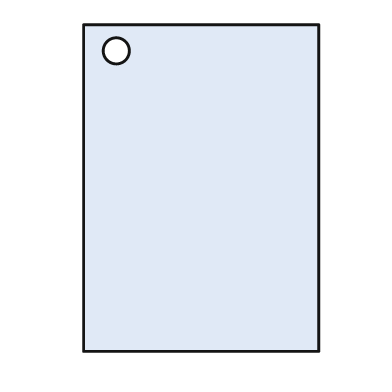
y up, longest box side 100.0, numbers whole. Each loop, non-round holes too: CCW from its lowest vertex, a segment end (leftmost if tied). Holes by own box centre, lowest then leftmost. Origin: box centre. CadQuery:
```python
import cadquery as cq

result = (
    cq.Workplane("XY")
    .moveTo(-36.0, -50.0)
    .lineTo(36.0, -50.0)
    .lineTo(36.0, 50.0)
    .lineTo(-36.0, 50.0)
    .close()
    .moveTo(-26.0, 42.0)
    .circle(4.0)
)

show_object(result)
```